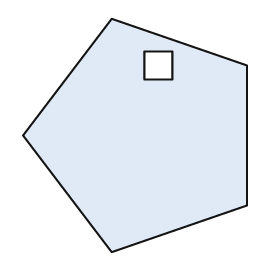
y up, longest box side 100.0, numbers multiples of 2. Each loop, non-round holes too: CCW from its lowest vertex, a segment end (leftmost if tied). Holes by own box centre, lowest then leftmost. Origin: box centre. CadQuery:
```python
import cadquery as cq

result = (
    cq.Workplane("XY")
    .moveTo(-10.0, -50.0)
    .lineTo(48.0, -30.0)
    .lineTo(48.0, 30.0)
    .lineTo(-10.0, 50.0)
    .lineTo(-48.0, 0.0)
    .close()
    .moveTo(4.0, 24.0)
    .lineTo(16.0, 24.0)
    .lineTo(16.0, 36.0)
    .lineTo(4.0, 36.0)
    .close()
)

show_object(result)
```